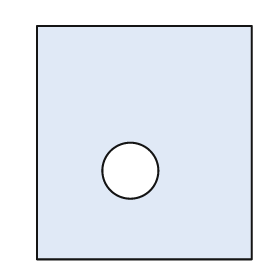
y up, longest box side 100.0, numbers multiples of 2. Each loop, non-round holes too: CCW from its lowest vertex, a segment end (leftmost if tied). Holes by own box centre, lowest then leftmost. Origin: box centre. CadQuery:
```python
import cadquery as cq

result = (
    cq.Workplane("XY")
    .moveTo(-46.0, -50.0)
    .lineTo(46.0, -50.0)
    .lineTo(46.0, 50.0)
    .lineTo(-46.0, 50.0)
    .close()
    .moveTo(-6.0, -12.0)
    .circle(12.0)
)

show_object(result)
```